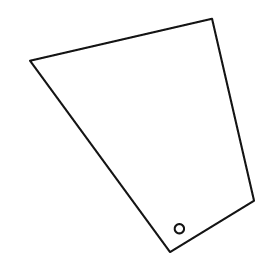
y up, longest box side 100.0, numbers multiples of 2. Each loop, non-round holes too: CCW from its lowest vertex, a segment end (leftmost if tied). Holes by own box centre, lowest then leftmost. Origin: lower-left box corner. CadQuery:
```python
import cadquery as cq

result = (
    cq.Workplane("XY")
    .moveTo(60.0, 0.0)
    .lineTo(96.0, 22.0)
    .lineTo(78.0, 100.0)
    .lineTo(0.0, 82.0)
    .close()
    .moveTo(64.0, 10.0)
    .circle(2.0)
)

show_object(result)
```